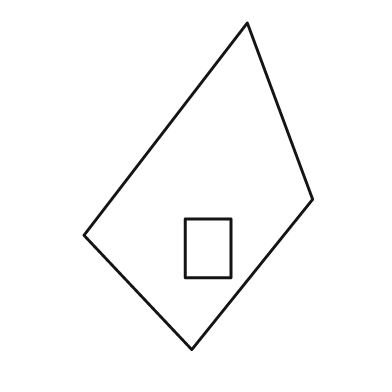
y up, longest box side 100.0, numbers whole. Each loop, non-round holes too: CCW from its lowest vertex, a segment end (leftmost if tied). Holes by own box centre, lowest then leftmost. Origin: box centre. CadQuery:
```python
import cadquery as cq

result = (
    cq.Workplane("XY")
    .moveTo(-2.0, -50.0)
    .lineTo(35.0, -4.0)
    .lineTo(15.0, 50.0)
    .lineTo(-35.0, -15.0)
    .close()
    .moveTo(-4.0, -28.0)
    .lineTo(10.0, -28.0)
    .lineTo(10.0, -10.0)
    .lineTo(-4.0, -10.0)
    .close()
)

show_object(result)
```